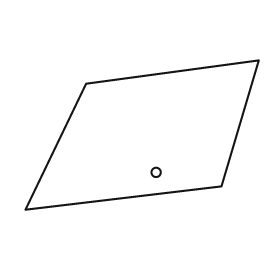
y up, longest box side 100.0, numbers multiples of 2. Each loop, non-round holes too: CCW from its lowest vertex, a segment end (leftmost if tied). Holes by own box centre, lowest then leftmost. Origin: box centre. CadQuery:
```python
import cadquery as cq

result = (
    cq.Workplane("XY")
    .moveTo(-50.0, -32.0)
    .lineTo(34.0, -22.0)
    .lineTo(50.0, 32.0)
    .lineTo(-24.0, 22.0)
    .close()
    .moveTo(6.0, -16.0)
    .circle(2.0)
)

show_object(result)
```